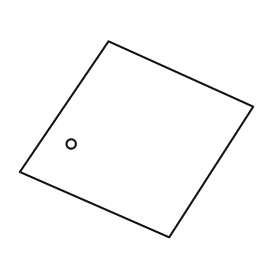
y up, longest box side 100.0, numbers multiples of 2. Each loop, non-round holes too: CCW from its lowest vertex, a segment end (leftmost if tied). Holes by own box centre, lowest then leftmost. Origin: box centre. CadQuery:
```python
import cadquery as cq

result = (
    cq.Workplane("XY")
    .moveTo(14.0, -42.0)
    .lineTo(50.0, 14.0)
    .lineTo(-12.0, 42.0)
    .lineTo(-50.0, -14.0)
    .close()
    .moveTo(-28.0, -2.0)
    .circle(2.0)
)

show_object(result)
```